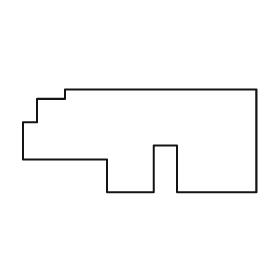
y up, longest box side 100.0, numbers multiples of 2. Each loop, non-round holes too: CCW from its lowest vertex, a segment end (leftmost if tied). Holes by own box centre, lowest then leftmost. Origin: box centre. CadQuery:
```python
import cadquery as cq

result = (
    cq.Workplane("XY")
    .moveTo(-14.0, -22.0)
    .lineTo(6.0, -22.0)
    .lineTo(6.0, -2.0)
    .lineTo(16.0, -2.0)
    .lineTo(16.0, -22.0)
    .lineTo(50.0, -22.0)
    .lineTo(50.0, 22.0)
    .lineTo(-32.0, 22.0)
    .lineTo(-32.0, 18.0)
    .lineTo(-44.0, 18.0)
    .lineTo(-44.0, 8.0)
    .lineTo(-50.0, 8.0)
    .lineTo(-50.0, -8.0)
    .lineTo(-14.0, -8.0)
    .close()
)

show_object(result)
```